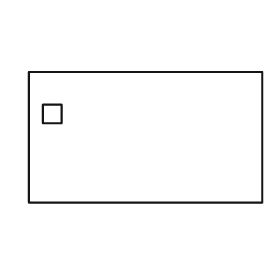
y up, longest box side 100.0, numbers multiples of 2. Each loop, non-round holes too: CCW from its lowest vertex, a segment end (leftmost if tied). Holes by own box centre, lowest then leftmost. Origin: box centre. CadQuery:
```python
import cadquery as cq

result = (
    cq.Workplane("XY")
    .moveTo(-50.0, -28.0)
    .lineTo(50.0, -28.0)
    .lineTo(50.0, 28.0)
    .lineTo(-50.0, 28.0)
    .close()
    .moveTo(-44.0, 6.0)
    .lineTo(-36.0, 6.0)
    .lineTo(-36.0, 14.0)
    .lineTo(-44.0, 14.0)
    .close()
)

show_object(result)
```